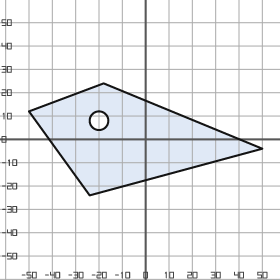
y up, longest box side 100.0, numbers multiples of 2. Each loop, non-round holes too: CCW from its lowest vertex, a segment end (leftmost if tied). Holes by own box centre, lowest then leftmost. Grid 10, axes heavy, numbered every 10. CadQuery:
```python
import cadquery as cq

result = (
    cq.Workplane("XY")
    .moveTo(-24.0, -24.0)
    .lineTo(50.0, -4.0)
    .lineTo(-18.0, 24.0)
    .lineTo(-50.0, 12.0)
    .close()
    .moveTo(-20.0, 8.0)
    .circle(4.0)
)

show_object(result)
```